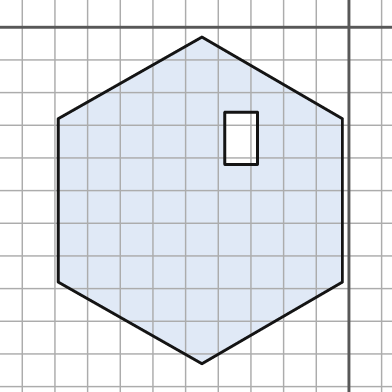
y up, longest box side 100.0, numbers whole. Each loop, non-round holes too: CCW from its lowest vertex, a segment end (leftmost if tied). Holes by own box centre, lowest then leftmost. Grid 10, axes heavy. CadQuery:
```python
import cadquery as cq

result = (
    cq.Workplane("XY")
    .moveTo(-45.0, -103.0)
    .lineTo(-2.0, -78.0)
    .lineTo(-2.0, -28.0)
    .lineTo(-45.0, -3.0)
    .lineTo(-89.0, -28.0)
    .lineTo(-89.0, -78.0)
    .close()
    .moveTo(-38.0, -42.0)
    .lineTo(-28.0, -42.0)
    .lineTo(-28.0, -26.0)
    .lineTo(-38.0, -26.0)
    .close()
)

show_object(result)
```